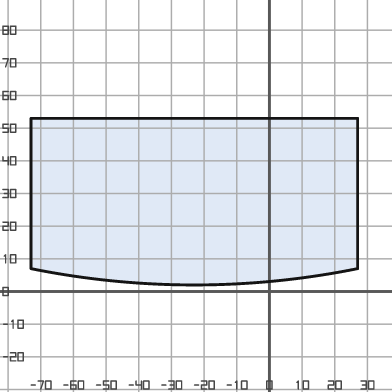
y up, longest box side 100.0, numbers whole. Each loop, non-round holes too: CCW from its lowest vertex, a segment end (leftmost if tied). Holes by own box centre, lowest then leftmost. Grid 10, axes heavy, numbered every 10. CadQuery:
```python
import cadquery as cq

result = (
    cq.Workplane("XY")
    .moveTo(-73.0, 7.0)
    .threePointArc((-23.0, 2.0), (27.0, 7.0))
    .lineTo(27.0, 53.0)
    .lineTo(-73.0, 53.0)
    .close()
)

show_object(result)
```